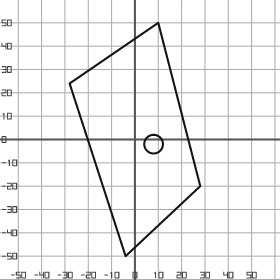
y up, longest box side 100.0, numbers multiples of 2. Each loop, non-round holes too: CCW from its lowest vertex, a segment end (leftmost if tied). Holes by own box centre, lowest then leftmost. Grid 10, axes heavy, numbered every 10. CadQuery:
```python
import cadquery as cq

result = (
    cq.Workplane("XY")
    .moveTo(-4.0, -50.0)
    .lineTo(28.0, -20.0)
    .lineTo(10.0, 50.0)
    .lineTo(-28.0, 24.0)
    .close()
    .moveTo(8.0, -2.0)
    .circle(4.0)
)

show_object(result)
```